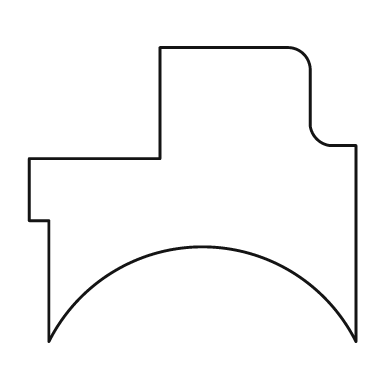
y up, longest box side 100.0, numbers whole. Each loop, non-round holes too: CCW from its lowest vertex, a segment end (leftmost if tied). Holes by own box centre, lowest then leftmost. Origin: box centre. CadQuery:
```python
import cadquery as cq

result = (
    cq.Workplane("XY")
    .moveTo(-44.0, -45.0)
    .threePointArc((3.0, -16.0), (50.0, -45.0))
    .lineTo(50.0, 15.0)
    .lineTo(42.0, 15.0)
    .threePointArc((38.0, 17.0), (36.0, 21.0))
    .lineTo(36.0, 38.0)
    .threePointArc((34.0, 43.0), (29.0, 45.0))
    .lineTo(-10.0, 45.0)
    .lineTo(-10.0, 11.0)
    .lineTo(-50.0, 11.0)
    .lineTo(-50.0, -8.0)
    .lineTo(-44.0, -8.0)
    .close()
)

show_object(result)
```